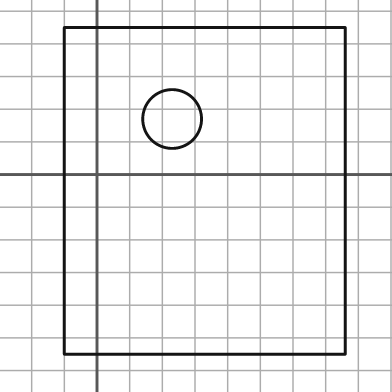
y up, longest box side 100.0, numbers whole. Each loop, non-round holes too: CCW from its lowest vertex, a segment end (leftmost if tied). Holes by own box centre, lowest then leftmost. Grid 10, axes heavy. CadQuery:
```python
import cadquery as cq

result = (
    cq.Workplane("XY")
    .moveTo(-10.0, -55.0)
    .lineTo(76.0, -55.0)
    .lineTo(76.0, 45.0)
    .lineTo(-10.0, 45.0)
    .close()
    .moveTo(23.0, 17.0)
    .circle(9.0)
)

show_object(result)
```